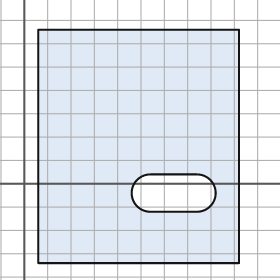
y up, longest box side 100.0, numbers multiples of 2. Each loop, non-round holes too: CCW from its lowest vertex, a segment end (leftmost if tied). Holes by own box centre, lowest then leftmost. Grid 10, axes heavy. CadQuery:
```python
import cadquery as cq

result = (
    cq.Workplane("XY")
    .moveTo(6.0, -34.0)
    .lineTo(92.0, -34.0)
    .lineTo(92.0, 66.0)
    .lineTo(6.0, 66.0)
    .close()
    .moveTo(54.0, -12.0)
    .lineTo(74.0, -12.0)
    .threePointArc((82.0, -4.0), (74.0, 4.0))
    .lineTo(54.0, 4.0)
    .threePointArc((46.0, -4.0), (54.0, -12.0))
    .close()
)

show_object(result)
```